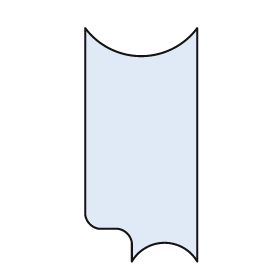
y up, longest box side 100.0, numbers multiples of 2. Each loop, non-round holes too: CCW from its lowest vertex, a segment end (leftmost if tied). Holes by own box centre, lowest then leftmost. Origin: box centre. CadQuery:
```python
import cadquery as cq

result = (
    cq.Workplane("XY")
    .moveTo(-4.0, -50.0)
    .threePointArc((10.0, -42.0), (24.0, -50.0))
    .lineTo(24.0, 50.0)
    .threePointArc((0.0, 38.0), (-24.0, 50.0))
    .lineTo(-24.0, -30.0)
    .threePointArc((-22.0, -34.0), (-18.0, -36.0))
    .lineTo(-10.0, -36.0)
    .threePointArc((-6.0, -38.0), (-4.0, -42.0))
    .close()
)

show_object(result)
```